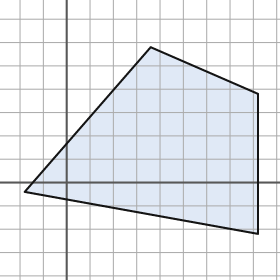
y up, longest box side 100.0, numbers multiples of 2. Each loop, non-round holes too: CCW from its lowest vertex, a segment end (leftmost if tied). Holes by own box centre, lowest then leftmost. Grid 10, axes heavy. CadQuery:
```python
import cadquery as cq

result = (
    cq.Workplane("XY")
    .moveTo(82.0, -22.0)
    .lineTo(82.0, 38.0)
    .lineTo(36.0, 58.0)
    .lineTo(-18.0, -4.0)
    .close()
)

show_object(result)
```